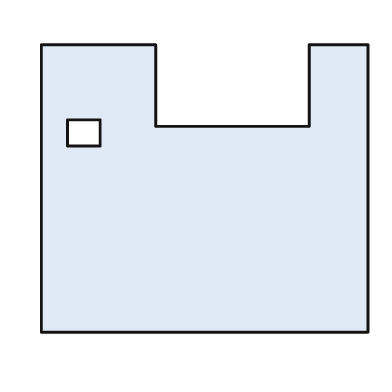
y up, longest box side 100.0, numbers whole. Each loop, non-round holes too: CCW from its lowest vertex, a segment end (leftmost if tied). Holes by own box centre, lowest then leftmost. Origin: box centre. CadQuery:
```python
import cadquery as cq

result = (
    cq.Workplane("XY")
    .moveTo(-50.0, -44.0)
    .lineTo(50.0, -44.0)
    .lineTo(50.0, 44.0)
    .lineTo(32.0, 44.0)
    .lineTo(32.0, 19.0)
    .lineTo(-15.0, 19.0)
    .lineTo(-15.0, 44.0)
    .lineTo(-50.0, 44.0)
    .close()
    .moveTo(-42.0, 13.0)
    .lineTo(-32.0, 13.0)
    .lineTo(-32.0, 21.0)
    .lineTo(-42.0, 21.0)
    .close()
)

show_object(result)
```